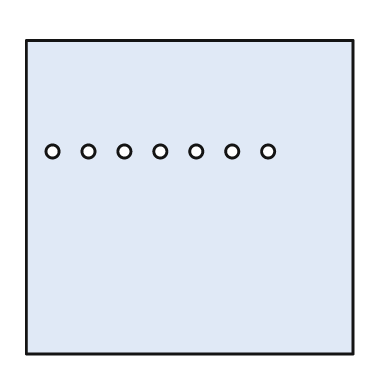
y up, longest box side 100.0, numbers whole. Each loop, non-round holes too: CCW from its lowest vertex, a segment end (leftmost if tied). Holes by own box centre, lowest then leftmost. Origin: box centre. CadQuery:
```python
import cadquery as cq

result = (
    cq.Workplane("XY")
    .moveTo(-50.0, -48.0)
    .lineTo(50.0, -48.0)
    .lineTo(50.0, 48.0)
    .lineTo(-50.0, 48.0)
    .close()
    .moveTo(-42.0, 14.0)
    .circle(2.0)
    .moveTo(-31.0, 14.0)
    .circle(2.0)
    .moveTo(-20.0, 14.0)
    .circle(2.0)
    .moveTo(-9.0, 14.0)
    .circle(2.0)
    .moveTo(2.0, 14.0)
    .circle(2.0)
    .moveTo(13.0, 14.0)
    .circle(2.0)
    .moveTo(24.0, 14.0)
    .circle(2.0)
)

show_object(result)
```